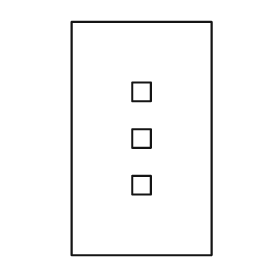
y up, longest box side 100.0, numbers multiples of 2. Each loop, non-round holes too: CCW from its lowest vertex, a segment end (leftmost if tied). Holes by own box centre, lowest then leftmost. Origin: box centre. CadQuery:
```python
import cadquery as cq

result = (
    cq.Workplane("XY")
    .moveTo(-30.0, -50.0)
    .lineTo(30.0, -50.0)
    .lineTo(30.0, 50.0)
    .lineTo(-30.0, 50.0)
    .close()
    .moveTo(-4.0, -24.0)
    .lineTo(4.0, -24.0)
    .lineTo(4.0, -16.0)
    .lineTo(-4.0, -16.0)
    .close()
    .moveTo(-4.0, -4.0)
    .lineTo(4.0, -4.0)
    .lineTo(4.0, 4.0)
    .lineTo(-4.0, 4.0)
    .close()
    .moveTo(-4.0, 16.0)
    .lineTo(4.0, 16.0)
    .lineTo(4.0, 24.0)
    .lineTo(-4.0, 24.0)
    .close()
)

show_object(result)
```